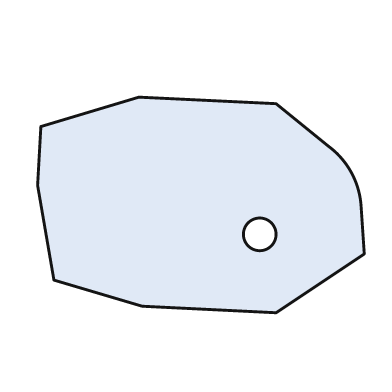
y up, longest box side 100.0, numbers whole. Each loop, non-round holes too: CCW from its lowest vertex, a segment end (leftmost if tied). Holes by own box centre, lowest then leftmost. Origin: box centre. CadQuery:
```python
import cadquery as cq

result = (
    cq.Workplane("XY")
    .moveTo(23.0, -33.0)
    .lineTo(50.0, -15.0)
    .lineTo(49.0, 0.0)
    .threePointArc((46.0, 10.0), (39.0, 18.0))
    .lineTo(23.0, 31.0)
    .lineTo(-19.0, 33.0)
    .lineTo(-49.0, 24.0)
    .lineTo(-50.0, 6.0)
    .lineTo(-45.0, -23.0)
    .lineTo(-18.0, -31.0)
    .close()
    .moveTo(18.0, -9.0)
    .circle(5.0)
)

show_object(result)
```